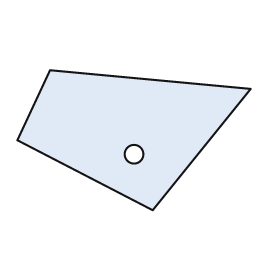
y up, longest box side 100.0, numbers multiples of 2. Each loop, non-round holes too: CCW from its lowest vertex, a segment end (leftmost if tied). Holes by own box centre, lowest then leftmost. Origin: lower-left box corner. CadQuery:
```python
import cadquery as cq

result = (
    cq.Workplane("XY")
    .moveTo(58.0, 0.0)
    .lineTo(100.0, 52.0)
    .lineTo(14.0, 60.0)
    .lineTo(0.0, 30.0)
    .close()
    .moveTo(50.0, 24.0)
    .circle(4.0)
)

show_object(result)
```